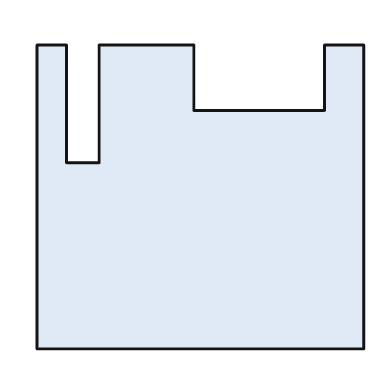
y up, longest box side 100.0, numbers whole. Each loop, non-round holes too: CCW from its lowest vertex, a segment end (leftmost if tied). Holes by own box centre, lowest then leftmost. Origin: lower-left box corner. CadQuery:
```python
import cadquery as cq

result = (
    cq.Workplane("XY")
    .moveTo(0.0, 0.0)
    .lineTo(100.0, 0.0)
    .lineTo(100.0, 93.0)
    .lineTo(88.0, 93.0)
    .lineTo(88.0, 73.0)
    .lineTo(48.0, 73.0)
    .lineTo(48.0, 93.0)
    .lineTo(19.0, 93.0)
    .lineTo(19.0, 57.0)
    .lineTo(9.0, 57.0)
    .lineTo(9.0, 93.0)
    .lineTo(0.0, 93.0)
    .close()
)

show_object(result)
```